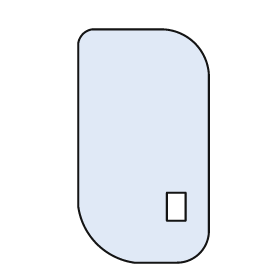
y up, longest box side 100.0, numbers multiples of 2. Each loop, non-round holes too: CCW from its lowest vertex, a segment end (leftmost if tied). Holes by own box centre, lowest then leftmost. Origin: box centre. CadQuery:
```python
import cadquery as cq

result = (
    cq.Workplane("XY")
    .moveTo(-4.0, -50.0)
    .lineTo(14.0, -50.0)
    .threePointArc((24.0, -46.0), (28.0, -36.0))
    .lineTo(28.0, 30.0)
    .threePointArc((22.0, 44.0), (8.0, 50.0))
    .lineTo(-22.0, 50.0)
    .threePointArc((-26.0, 48.0), (-28.0, 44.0))
    .lineTo(-28.0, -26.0)
    .threePointArc((-20.0, -42.0), (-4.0, -50.0))
    .close()
    .moveTo(10.0, -32.0)
    .lineTo(18.0, -32.0)
    .lineTo(18.0, -20.0)
    .lineTo(10.0, -20.0)
    .close()
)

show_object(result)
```